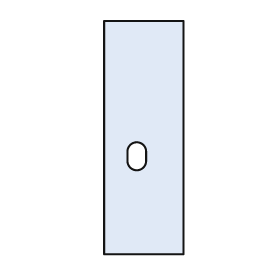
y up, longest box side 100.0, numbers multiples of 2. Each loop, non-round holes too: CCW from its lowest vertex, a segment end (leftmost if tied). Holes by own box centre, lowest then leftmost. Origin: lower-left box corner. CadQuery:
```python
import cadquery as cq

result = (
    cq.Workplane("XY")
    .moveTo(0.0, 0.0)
    .lineTo(34.0, 0.0)
    .lineTo(34.0, 100.0)
    .lineTo(0.0, 100.0)
    .close()
    .moveTo(10.0, 40.0)
    .threePointArc((14.0, 36.0), (18.0, 40.0))
    .lineTo(18.0, 44.0)
    .threePointArc((14.0, 48.0), (10.0, 44.0))
    .close()
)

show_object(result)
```